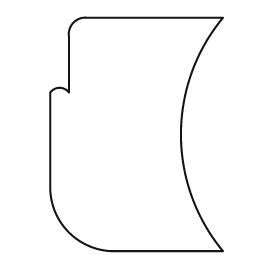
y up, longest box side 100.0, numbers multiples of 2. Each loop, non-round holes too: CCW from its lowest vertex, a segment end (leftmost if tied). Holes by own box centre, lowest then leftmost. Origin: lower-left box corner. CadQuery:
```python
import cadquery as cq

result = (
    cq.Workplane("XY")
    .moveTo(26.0, 0.0)
    .lineTo(74.0, 0.0)
    .threePointArc((56.0, 50.0), (74.0, 100.0))
    .lineTo(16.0, 100.0)
    .threePointArc((10.0, 98.0), (8.0, 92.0))
    .lineTo(8.0, 68.0)
    .threePointArc((4.0, 70.0), (0.0, 68.0))
    .lineTo(0.0, 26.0)
    .threePointArc((8.0, 8.0), (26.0, 0.0))
    .close()
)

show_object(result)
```